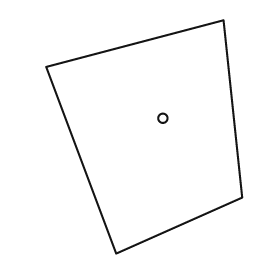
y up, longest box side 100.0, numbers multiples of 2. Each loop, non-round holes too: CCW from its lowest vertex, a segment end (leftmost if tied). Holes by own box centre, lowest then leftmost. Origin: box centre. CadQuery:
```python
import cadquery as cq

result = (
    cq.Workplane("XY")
    .moveTo(-12.0, -50.0)
    .lineTo(42.0, -26.0)
    .lineTo(34.0, 50.0)
    .lineTo(-42.0, 30.0)
    .close()
    .moveTo(8.0, 8.0)
    .circle(2.0)
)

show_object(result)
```